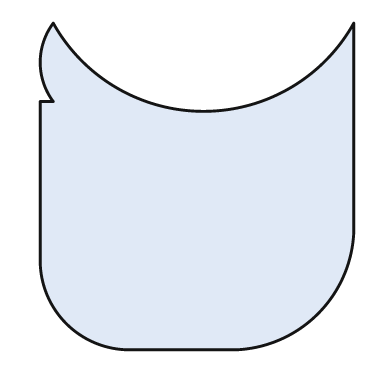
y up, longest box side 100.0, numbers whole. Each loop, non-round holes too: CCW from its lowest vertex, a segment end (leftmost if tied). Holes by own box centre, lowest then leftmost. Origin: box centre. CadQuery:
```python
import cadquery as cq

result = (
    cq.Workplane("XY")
    .moveTo(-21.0, -50.0)
    .lineTo(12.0, -50.0)
    .threePointArc((37.0, -39.0), (48.0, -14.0))
    .lineTo(48.0, 50.0)
    .threePointArc((2.0, 23.0), (-44.0, 50.0))
    .threePointArc((-48.0, 38.0), (-44.0, 26.0))
    .lineTo(-48.0, 26.0)
    .lineTo(-48.0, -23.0)
    .threePointArc((-40.0, -42.0), (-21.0, -50.0))
    .close()
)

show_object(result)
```